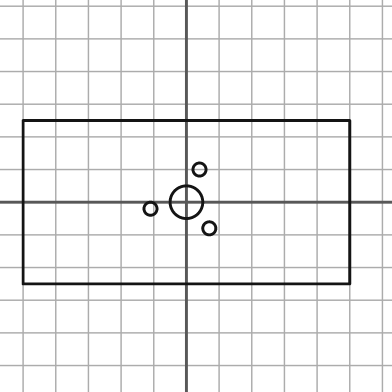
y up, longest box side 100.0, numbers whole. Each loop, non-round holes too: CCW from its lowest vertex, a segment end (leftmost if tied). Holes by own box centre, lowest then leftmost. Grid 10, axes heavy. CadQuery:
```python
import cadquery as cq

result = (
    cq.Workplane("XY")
    .moveTo(-50.0, -25.0)
    .lineTo(50.0, -25.0)
    .lineTo(50.0, 25.0)
    .lineTo(-50.0, 25.0)
    .close()
    .moveTo(7.0, -8.0)
    .circle(2.0)
    .moveTo(-11.0, -2.0)
    .circle(2.0)
    .moveTo(0.0, 0.0)
    .circle(5.0)
    .moveTo(4.0, 10.0)
    .circle(2.0)
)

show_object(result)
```